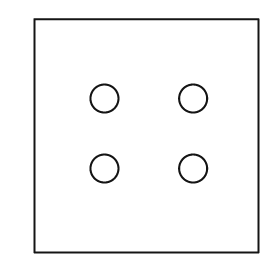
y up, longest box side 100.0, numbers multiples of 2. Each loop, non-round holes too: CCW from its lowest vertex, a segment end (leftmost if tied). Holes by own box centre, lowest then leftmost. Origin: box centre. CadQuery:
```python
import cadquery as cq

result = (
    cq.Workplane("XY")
    .moveTo(-48.0, -50.0)
    .lineTo(48.0, -50.0)
    .lineTo(48.0, 50.0)
    .lineTo(-48.0, 50.0)
    .close()
    .moveTo(-18.0, -14.0)
    .circle(6.0)
    .moveTo(20.0, -14.0)
    .circle(6.0)
    .moveTo(-18.0, 16.0)
    .circle(6.0)
    .moveTo(20.0, 16.0)
    .circle(6.0)
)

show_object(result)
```